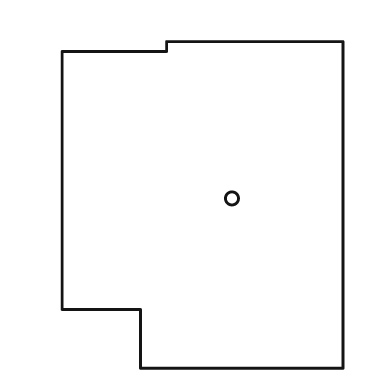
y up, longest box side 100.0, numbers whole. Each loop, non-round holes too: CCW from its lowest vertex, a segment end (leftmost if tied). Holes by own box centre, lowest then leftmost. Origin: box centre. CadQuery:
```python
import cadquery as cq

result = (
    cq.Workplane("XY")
    .moveTo(-19.0, -50.0)
    .lineTo(43.0, -50.0)
    .lineTo(43.0, 50.0)
    .lineTo(-11.0, 50.0)
    .lineTo(-11.0, 47.0)
    .lineTo(-43.0, 47.0)
    .lineTo(-43.0, -32.0)
    .lineTo(-19.0, -32.0)
    .close()
    .moveTo(9.0, 2.0)
    .circle(2.0)
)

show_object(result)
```